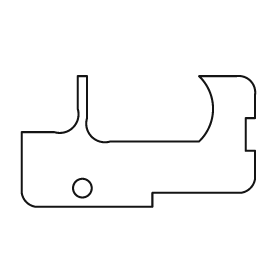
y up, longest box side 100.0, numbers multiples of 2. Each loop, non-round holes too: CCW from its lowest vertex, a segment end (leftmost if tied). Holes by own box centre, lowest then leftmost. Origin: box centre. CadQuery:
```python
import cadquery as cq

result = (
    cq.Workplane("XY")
    .moveTo(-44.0, -28.0)
    .lineTo(6.0, -28.0)
    .lineTo(6.0, -22.0)
    .lineTo(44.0, -22.0)
    .threePointArc((48.0, -20.0), (50.0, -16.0))
    .lineTo(50.0, -4.0)
    .lineTo(46.0, -4.0)
    .lineTo(46.0, 10.0)
    .lineTo(50.0, 10.0)
    .lineTo(50.0, 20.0)
    .threePointArc((48.0, 26.0), (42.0, 28.0))
    .lineTo(26.0, 28.0)
    .threePointArc((32.0, 14.0), (26.0, 0.0))
    .lineTo(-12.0, 0.0)
    .threePointArc((-20.0, 2.0), (-22.0, 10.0))
    .lineTo(-22.0, 28.0)
    .lineTo(-26.0, 28.0)
    .lineTo(-26.0, 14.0)
    .threePointArc((-28.0, 6.0), (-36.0, 4.0))
    .lineTo(-50.0, 4.0)
    .lineTo(-50.0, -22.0)
    .threePointArc((-48.0, -26.0), (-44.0, -28.0))
    .close()
    .moveTo(-24.0, -20.0)
    .circle(4.0)
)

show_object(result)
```